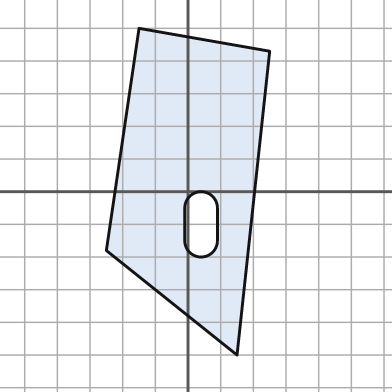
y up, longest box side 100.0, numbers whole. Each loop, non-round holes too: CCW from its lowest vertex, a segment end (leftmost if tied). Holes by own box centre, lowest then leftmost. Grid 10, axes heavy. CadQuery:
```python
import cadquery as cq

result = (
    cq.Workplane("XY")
    .moveTo(15.0, -50.0)
    .lineTo(25.0, 43.0)
    .lineTo(-15.0, 50.0)
    .lineTo(-25.0, -18.0)
    .close()
    .moveTo(-1.0, -15.0)
    .threePointArc((4.0, -20.0), (9.0, -15.0))
    .lineTo(9.0, -5.0)
    .threePointArc((4.0, 0.0), (-1.0, -5.0))
    .close()
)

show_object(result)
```